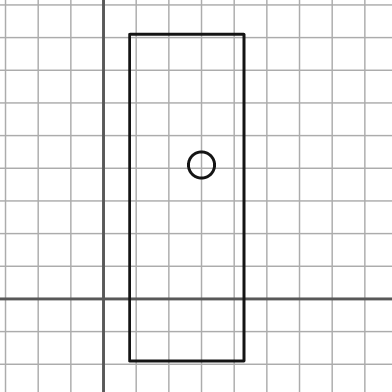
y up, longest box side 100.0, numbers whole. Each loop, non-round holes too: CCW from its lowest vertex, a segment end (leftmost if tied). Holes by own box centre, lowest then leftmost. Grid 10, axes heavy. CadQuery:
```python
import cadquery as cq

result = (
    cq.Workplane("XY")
    .moveTo(8.0, -19.0)
    .lineTo(43.0, -19.0)
    .lineTo(43.0, 81.0)
    .lineTo(8.0, 81.0)
    .close()
    .moveTo(30.0, 41.0)
    .circle(4.0)
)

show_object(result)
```